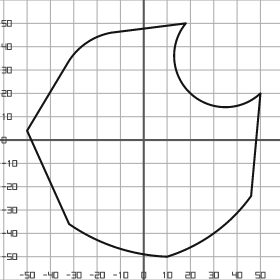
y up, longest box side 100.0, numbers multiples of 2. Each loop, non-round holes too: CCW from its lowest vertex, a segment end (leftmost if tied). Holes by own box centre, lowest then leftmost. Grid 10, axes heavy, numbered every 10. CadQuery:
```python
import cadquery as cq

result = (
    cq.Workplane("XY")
    .moveTo(10.0, -50.0)
    .threePointArc((30.0, -40.0), (46.0, -24.0))
    .lineTo(50.0, 20.0)
    .threePointArc((20.0, 20.0), (18.0, 50.0))
    .lineTo(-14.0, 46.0)
    .threePointArc((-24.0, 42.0), (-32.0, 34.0))
    .lineTo(-50.0, 4.0)
    .lineTo(-32.0, -36.0)
    .threePointArc((-12.0, -46.0), (10.0, -50.0))
    .close()
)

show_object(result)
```